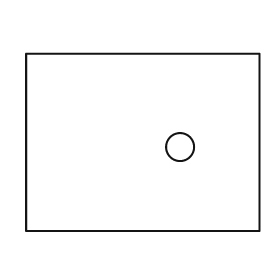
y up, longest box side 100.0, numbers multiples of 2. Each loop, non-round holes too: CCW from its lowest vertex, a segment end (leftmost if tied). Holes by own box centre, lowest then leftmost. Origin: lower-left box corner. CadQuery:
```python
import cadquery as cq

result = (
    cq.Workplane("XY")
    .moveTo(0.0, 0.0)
    .lineTo(100.0, 0.0)
    .lineTo(100.0, 76.0)
    .lineTo(0.0, 76.0)
    .close()
    .moveTo(66.0, 36.0)
    .circle(6.0)
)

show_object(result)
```